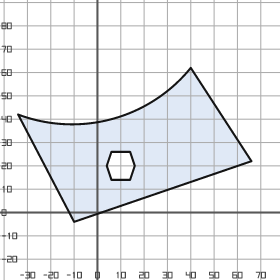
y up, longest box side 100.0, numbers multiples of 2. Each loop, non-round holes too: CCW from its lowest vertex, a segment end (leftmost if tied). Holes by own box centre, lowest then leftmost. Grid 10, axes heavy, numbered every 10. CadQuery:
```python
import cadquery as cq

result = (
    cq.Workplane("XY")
    .moveTo(-10.0, -4.0)
    .lineTo(66.0, 22.0)
    .lineTo(40.0, 62.0)
    .threePointArc((6.0, 40.0), (-34.0, 42.0))
    .close()
    .moveTo(6.0, 14.0)
    .lineTo(14.0, 14.0)
    .lineTo(16.0, 20.0)
    .lineTo(14.0, 26.0)
    .lineTo(6.0, 26.0)
    .lineTo(4.0, 20.0)
    .close()
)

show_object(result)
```